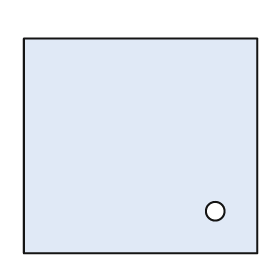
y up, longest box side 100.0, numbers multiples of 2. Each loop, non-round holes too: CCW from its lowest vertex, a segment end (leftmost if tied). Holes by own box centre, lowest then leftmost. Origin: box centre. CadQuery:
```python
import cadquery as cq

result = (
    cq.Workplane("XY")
    .moveTo(-50.0, -46.0)
    .lineTo(50.0, -46.0)
    .lineTo(50.0, 46.0)
    .lineTo(-50.0, 46.0)
    .close()
    .moveTo(32.0, -28.0)
    .circle(4.0)
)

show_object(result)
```